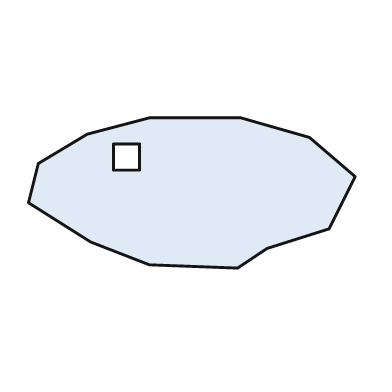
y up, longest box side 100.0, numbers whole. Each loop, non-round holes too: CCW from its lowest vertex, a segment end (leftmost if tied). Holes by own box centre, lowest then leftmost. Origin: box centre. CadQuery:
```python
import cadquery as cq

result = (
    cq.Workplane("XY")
    .moveTo(14.0, -23.0)
    .lineTo(23.0, -17.0)
    .lineTo(42.0, -11.0)
    .lineTo(50.0, 5.0)
    .lineTo(36.0, 17.0)
    .lineTo(15.0, 23.0)
    .lineTo(-13.0, 23.0)
    .lineTo(-32.0, 18.0)
    .lineTo(-47.0, 9.0)
    .lineTo(-50.0, -3.0)
    .lineTo(-31.0, -15.0)
    .lineTo(-13.0, -22.0)
    .close()
    .moveTo(-24.0, 7.0)
    .lineTo(-16.0, 7.0)
    .lineTo(-16.0, 15.0)
    .lineTo(-24.0, 15.0)
    .close()
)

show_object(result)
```